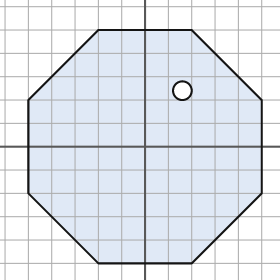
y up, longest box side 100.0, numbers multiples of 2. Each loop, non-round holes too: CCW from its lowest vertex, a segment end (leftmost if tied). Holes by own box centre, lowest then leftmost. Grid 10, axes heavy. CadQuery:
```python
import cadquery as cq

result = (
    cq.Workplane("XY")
    .moveTo(-20.0, -50.0)
    .lineTo(20.0, -50.0)
    .lineTo(50.0, -20.0)
    .lineTo(50.0, 20.0)
    .lineTo(20.0, 50.0)
    .lineTo(-20.0, 50.0)
    .lineTo(-50.0, 20.0)
    .lineTo(-50.0, -20.0)
    .close()
    .moveTo(16.0, 24.0)
    .circle(4.0)
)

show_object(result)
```